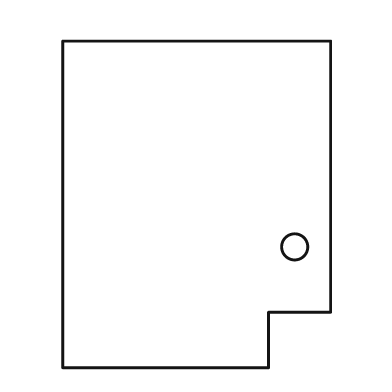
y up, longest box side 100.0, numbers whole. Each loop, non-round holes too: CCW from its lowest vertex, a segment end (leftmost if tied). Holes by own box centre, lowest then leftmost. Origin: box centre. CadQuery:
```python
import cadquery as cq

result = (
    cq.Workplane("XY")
    .moveTo(-41.0, -50.0)
    .lineTo(22.0, -50.0)
    .lineTo(22.0, -33.0)
    .lineTo(41.0, -33.0)
    .lineTo(41.0, 50.0)
    .lineTo(-41.0, 50.0)
    .close()
    .moveTo(30.0, -13.0)
    .circle(4.0)
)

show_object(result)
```